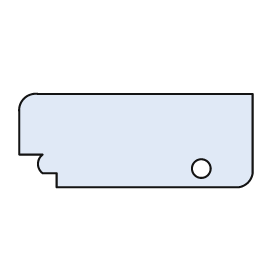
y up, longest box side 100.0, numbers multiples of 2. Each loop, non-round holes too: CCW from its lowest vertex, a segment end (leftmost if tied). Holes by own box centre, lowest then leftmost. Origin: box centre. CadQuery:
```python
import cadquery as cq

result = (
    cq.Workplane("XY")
    .moveTo(-34.0, -20.0)
    .lineTo(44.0, -20.0)
    .threePointArc((48.0, -18.0), (50.0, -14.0))
    .lineTo(50.0, 20.0)
    .lineTo(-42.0, 20.0)
    .threePointArc((-48.0, 18.0), (-50.0, 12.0))
    .lineTo(-50.0, -6.0)
    .lineTo(-40.0, -6.0)
    .threePointArc((-42.0, -10.0), (-40.0, -14.0))
    .lineTo(-34.0, -14.0)
    .close()
    .moveTo(28.0, -12.0)
    .circle(4.0)
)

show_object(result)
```